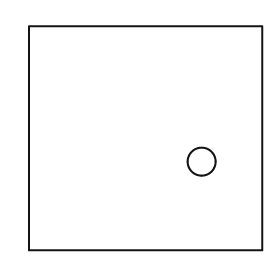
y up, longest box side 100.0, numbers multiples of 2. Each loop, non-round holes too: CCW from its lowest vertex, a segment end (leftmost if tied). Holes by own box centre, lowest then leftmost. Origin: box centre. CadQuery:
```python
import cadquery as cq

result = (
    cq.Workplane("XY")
    .moveTo(-50.0, -48.0)
    .lineTo(50.0, -48.0)
    .lineTo(50.0, 48.0)
    .lineTo(-50.0, 48.0)
    .close()
    .moveTo(24.0, -10.0)
    .circle(6.0)
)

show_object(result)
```